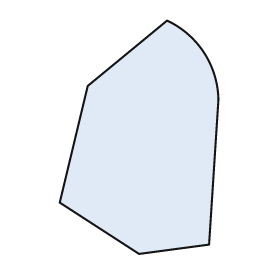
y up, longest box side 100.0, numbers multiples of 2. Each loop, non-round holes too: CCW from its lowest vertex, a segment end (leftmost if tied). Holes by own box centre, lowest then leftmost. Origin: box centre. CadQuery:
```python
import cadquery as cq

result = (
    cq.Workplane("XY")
    .moveTo(0.0, -50.0)
    .lineTo(30.0, -46.0)
    .lineTo(34.0, 16.0)
    .threePointArc((28.0, 36.0), (12.0, 50.0))
    .lineTo(-22.0, 22.0)
    .lineTo(-34.0, -28.0)
    .close()
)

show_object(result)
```